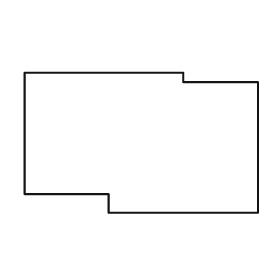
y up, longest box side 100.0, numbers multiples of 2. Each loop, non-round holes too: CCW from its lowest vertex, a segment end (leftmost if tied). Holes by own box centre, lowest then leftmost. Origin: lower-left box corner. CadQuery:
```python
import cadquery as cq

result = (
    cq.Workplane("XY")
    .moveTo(36.0, 0.0)
    .lineTo(100.0, 0.0)
    .lineTo(100.0, 56.0)
    .lineTo(68.0, 56.0)
    .lineTo(68.0, 60.0)
    .lineTo(0.0, 60.0)
    .lineTo(0.0, 8.0)
    .lineTo(36.0, 8.0)
    .close()
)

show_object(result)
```